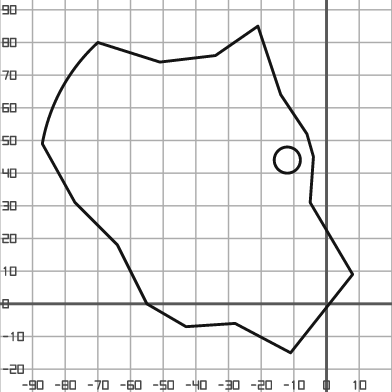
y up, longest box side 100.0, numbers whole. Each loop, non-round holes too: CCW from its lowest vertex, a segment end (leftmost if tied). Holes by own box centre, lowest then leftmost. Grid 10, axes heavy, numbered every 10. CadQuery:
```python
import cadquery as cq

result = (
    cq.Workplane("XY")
    .moveTo(-11.0, -15.0)
    .lineTo(8.0, 9.0)
    .lineTo(-5.0, 31.0)
    .lineTo(-4.0, 45.0)
    .lineTo(-6.0, 52.0)
    .lineTo(-14.0, 64.0)
    .lineTo(-21.0, 85.0)
    .lineTo(-34.0, 76.0)
    .lineTo(-51.0, 74.0)
    .lineTo(-70.0, 80.0)
    .threePointArc((-81.0, 66.0), (-87.0, 49.0))
    .lineTo(-77.0, 31.0)
    .lineTo(-64.0, 18.0)
    .lineTo(-55.0, 0.0)
    .lineTo(-43.0, -7.0)
    .lineTo(-28.0, -6.0)
    .close()
    .moveTo(-12.0, 44.0)
    .circle(4.0)
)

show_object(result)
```